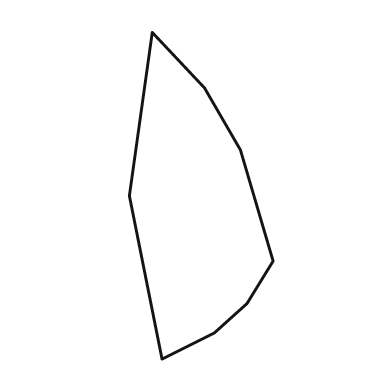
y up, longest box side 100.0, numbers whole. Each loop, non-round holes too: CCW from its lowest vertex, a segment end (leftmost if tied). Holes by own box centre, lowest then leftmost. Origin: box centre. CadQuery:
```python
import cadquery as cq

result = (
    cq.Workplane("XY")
    .moveTo(-12.0, -50.0)
    .lineTo(4.0, -42.0)
    .lineTo(14.0, -33.0)
    .lineTo(22.0, -20.0)
    .lineTo(12.0, 14.0)
    .lineTo(1.0, 33.0)
    .lineTo(-15.0, 50.0)
    .lineTo(-22.0, 0.0)
    .close()
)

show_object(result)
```